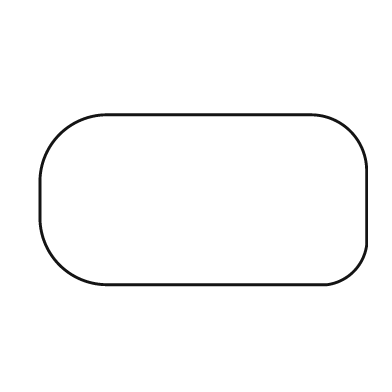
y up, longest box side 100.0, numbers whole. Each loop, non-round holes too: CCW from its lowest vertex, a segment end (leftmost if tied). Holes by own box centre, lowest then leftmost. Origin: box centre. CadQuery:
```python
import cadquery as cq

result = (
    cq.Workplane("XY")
    .moveTo(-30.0, -26.0)
    .lineTo(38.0, -26.0)
    .threePointArc((46.0, -22.0), (50.0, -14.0))
    .lineTo(50.0, 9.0)
    .threePointArc((45.0, 21.0), (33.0, 26.0))
    .lineTo(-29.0, 26.0)
    .threePointArc((-44.0, 20.0), (-50.0, 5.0))
    .lineTo(-50.0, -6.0)
    .threePointArc((-44.0, -20.0), (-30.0, -26.0))
    .close()
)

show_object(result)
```